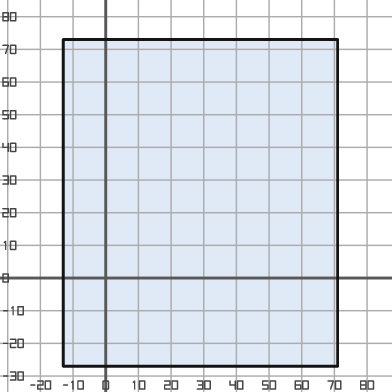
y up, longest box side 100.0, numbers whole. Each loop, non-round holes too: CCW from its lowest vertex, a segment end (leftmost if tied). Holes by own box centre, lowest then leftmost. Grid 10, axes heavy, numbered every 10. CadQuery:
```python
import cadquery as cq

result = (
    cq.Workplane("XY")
    .moveTo(-13.0, -27.0)
    .lineTo(71.0, -27.0)
    .lineTo(71.0, 73.0)
    .lineTo(-13.0, 73.0)
    .close()
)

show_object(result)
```